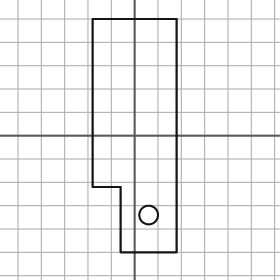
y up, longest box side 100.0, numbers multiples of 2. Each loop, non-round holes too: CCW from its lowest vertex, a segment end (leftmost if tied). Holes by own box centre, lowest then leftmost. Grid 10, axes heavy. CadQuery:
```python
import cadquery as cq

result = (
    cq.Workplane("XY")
    .moveTo(-6.0, -50.0)
    .lineTo(18.0, -50.0)
    .lineTo(18.0, 50.0)
    .lineTo(-18.0, 50.0)
    .lineTo(-18.0, -22.0)
    .lineTo(-6.0, -22.0)
    .close()
    .moveTo(6.0, -34.0)
    .circle(4.0)
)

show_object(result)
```